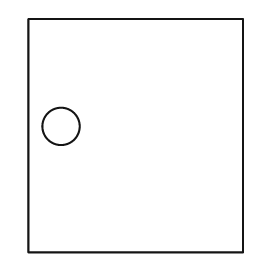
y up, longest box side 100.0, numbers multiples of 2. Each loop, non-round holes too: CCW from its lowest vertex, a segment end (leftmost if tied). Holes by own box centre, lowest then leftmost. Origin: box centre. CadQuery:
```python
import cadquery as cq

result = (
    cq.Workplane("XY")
    .moveTo(-46.0, -50.0)
    .lineTo(46.0, -50.0)
    .lineTo(46.0, 50.0)
    .lineTo(-46.0, 50.0)
    .close()
    .moveTo(-32.0, 4.0)
    .circle(8.0)
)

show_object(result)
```